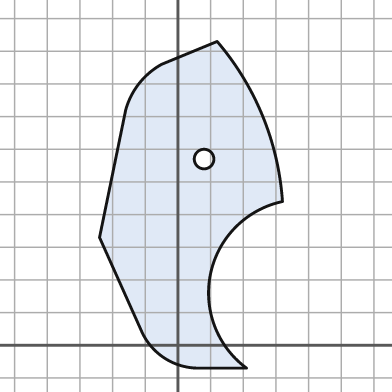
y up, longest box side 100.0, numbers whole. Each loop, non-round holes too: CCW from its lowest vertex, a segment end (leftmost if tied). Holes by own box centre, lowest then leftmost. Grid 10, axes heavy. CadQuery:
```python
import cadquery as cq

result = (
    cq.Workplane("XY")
    .moveTo(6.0, -7.0)
    .lineTo(21.0, -7.0)
    .threePointArc((10.0, 22.0), (32.0, 44.0))
    .threePointArc((26.0, 70.0), (12.0, 93.0))
    .lineTo(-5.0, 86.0)
    .threePointArc((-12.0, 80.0), (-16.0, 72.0))
    .lineTo(-24.0, 33.0)
    .lineTo(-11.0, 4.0)
    .threePointArc((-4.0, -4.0), (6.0, -7.0))
    .close()
    .moveTo(8.0, 57.0)
    .circle(3.0)
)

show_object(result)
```